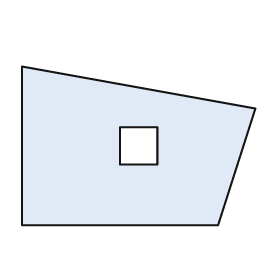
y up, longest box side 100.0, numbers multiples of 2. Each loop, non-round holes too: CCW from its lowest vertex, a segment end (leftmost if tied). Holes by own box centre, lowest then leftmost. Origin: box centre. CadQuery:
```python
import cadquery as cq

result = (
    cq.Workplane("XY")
    .moveTo(-50.0, -34.0)
    .lineTo(34.0, -34.0)
    .lineTo(50.0, 16.0)
    .lineTo(-50.0, 34.0)
    .close()
    .moveTo(-8.0, -8.0)
    .lineTo(8.0, -8.0)
    .lineTo(8.0, 8.0)
    .lineTo(-8.0, 8.0)
    .close()
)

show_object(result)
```